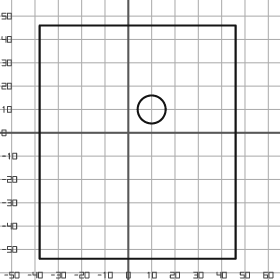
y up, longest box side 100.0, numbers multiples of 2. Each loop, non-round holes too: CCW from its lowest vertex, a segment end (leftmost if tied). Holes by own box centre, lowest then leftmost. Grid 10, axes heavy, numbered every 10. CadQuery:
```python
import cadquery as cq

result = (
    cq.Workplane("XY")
    .moveTo(-38.0, -54.0)
    .lineTo(46.0, -54.0)
    .lineTo(46.0, 46.0)
    .lineTo(-38.0, 46.0)
    .close()
    .moveTo(10.0, 10.0)
    .circle(6.0)
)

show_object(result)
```